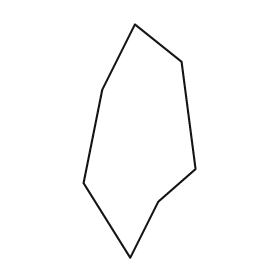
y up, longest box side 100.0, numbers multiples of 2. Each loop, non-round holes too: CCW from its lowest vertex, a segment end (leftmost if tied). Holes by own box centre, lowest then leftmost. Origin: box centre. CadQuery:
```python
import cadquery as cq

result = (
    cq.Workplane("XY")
    .moveTo(-4.0, -50.0)
    .lineTo(8.0, -26.0)
    .lineTo(24.0, -12.0)
    .lineTo(18.0, 34.0)
    .lineTo(-2.0, 50.0)
    .lineTo(-16.0, 22.0)
    .lineTo(-24.0, -18.0)
    .close()
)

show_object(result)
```